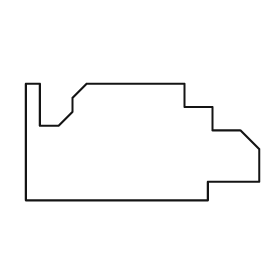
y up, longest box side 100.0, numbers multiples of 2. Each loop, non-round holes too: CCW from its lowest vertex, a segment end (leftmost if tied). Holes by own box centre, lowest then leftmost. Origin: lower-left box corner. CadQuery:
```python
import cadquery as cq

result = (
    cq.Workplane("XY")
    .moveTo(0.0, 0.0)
    .lineTo(78.0, 0.0)
    .lineTo(78.0, 8.0)
    .lineTo(100.0, 8.0)
    .lineTo(100.0, 22.0)
    .lineTo(92.0, 30.0)
    .lineTo(80.0, 30.0)
    .lineTo(80.0, 40.0)
    .lineTo(68.0, 40.0)
    .lineTo(68.0, 50.0)
    .lineTo(26.0, 50.0)
    .lineTo(20.0, 44.0)
    .lineTo(20.0, 38.0)
    .lineTo(14.0, 32.0)
    .lineTo(6.0, 32.0)
    .lineTo(6.0, 50.0)
    .lineTo(0.0, 50.0)
    .close()
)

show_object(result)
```